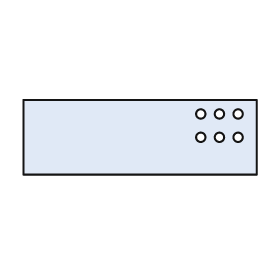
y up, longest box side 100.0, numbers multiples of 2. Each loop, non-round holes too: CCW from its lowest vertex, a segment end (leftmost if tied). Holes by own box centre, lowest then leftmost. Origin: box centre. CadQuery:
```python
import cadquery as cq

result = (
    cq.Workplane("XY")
    .moveTo(-50.0, -16.0)
    .lineTo(50.0, -16.0)
    .lineTo(50.0, 16.0)
    .lineTo(-50.0, 16.0)
    .close()
    .moveTo(26.0, 0.0)
    .circle(2.0)
    .moveTo(34.0, 0.0)
    .circle(2.0)
    .moveTo(42.0, 0.0)
    .circle(2.0)
    .moveTo(26.0, 10.0)
    .circle(2.0)
    .moveTo(34.0, 10.0)
    .circle(2.0)
    .moveTo(42.0, 10.0)
    .circle(2.0)
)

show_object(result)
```